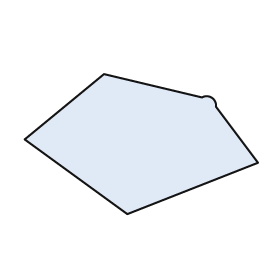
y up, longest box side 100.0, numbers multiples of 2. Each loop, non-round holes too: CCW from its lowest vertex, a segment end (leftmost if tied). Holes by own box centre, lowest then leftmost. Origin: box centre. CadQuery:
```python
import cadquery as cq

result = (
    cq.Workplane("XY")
    .moveTo(-6.0, -30.0)
    .lineTo(50.0, -8.0)
    .lineTo(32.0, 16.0)
    .threePointArc((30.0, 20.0), (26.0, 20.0))
    .lineTo(-16.0, 30.0)
    .lineTo(-50.0, 2.0)
    .close()
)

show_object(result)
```